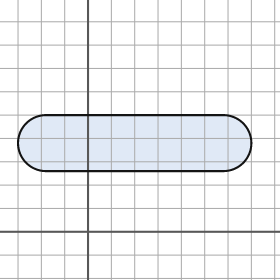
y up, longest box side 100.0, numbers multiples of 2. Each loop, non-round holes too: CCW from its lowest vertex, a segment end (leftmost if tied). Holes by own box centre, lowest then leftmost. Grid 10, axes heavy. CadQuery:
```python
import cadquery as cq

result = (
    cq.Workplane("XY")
    .moveTo(-18.0, 26.0)
    .lineTo(58.0, 26.0)
    .threePointArc((70.0, 38.0), (58.0, 50.0))
    .lineTo(-18.0, 50.0)
    .threePointArc((-30.0, 38.0), (-18.0, 26.0))
    .close()
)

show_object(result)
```